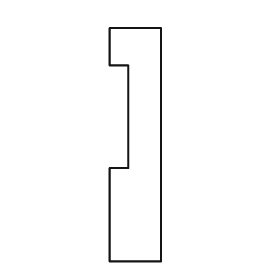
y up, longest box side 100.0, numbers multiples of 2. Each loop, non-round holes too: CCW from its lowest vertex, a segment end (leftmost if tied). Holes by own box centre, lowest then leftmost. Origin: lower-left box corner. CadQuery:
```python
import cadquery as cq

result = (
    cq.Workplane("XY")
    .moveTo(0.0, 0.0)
    .lineTo(22.0, 0.0)
    .lineTo(22.0, 100.0)
    .lineTo(0.0, 100.0)
    .lineTo(0.0, 84.0)
    .lineTo(8.0, 84.0)
    .lineTo(8.0, 40.0)
    .lineTo(0.0, 40.0)
    .close()
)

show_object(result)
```